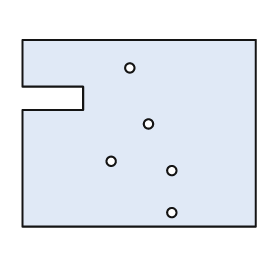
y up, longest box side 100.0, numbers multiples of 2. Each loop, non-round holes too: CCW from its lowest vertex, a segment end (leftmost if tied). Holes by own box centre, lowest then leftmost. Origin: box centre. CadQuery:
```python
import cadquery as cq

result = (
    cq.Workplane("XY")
    .moveTo(-50.0, -40.0)
    .lineTo(50.0, -40.0)
    .lineTo(50.0, 40.0)
    .lineTo(-50.0, 40.0)
    .lineTo(-50.0, 20.0)
    .lineTo(-24.0, 20.0)
    .lineTo(-24.0, 10.0)
    .lineTo(-50.0, 10.0)
    .close()
    .moveTo(14.0, -34.0)
    .circle(2.0)
    .moveTo(14.0, -16.0)
    .circle(2.0)
    .moveTo(-12.0, -12.0)
    .circle(2.0)
    .moveTo(4.0, 4.0)
    .circle(2.0)
    .moveTo(-4.0, 28.0)
    .circle(2.0)
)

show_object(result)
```